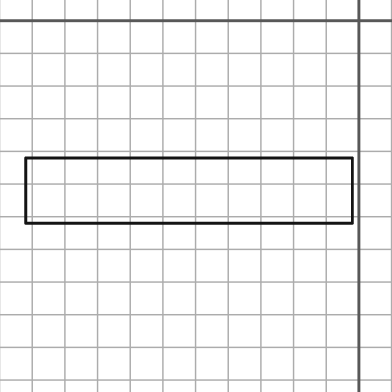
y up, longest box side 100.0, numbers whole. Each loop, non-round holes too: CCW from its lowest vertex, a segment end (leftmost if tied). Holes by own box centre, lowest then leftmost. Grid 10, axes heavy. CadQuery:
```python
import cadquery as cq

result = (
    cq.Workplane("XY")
    .moveTo(-102.0, -62.0)
    .lineTo(-2.0, -62.0)
    .lineTo(-2.0, -42.0)
    .lineTo(-102.0, -42.0)
    .close()
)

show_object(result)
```